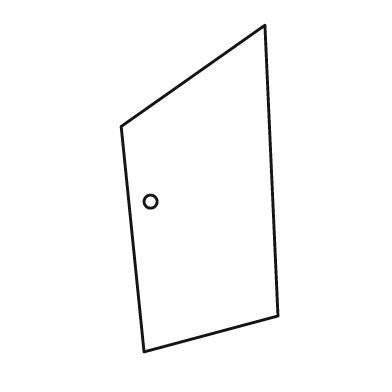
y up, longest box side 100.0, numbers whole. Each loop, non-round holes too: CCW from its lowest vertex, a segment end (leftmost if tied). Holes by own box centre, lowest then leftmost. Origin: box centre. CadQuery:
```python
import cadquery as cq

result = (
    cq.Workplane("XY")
    .moveTo(-17.0, -50.0)
    .lineTo(24.0, -39.0)
    .lineTo(20.0, 50.0)
    .lineTo(-24.0, 19.0)
    .close()
    .moveTo(-15.0, -4.0)
    .circle(2.0)
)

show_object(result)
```